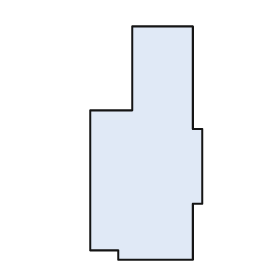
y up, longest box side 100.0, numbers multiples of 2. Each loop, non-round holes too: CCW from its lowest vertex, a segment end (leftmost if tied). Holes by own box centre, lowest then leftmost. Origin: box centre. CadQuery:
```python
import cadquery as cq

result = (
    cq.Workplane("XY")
    .moveTo(-12.0, -50.0)
    .lineTo(20.0, -50.0)
    .lineTo(20.0, -26.0)
    .lineTo(24.0, -26.0)
    .lineTo(24.0, 6.0)
    .lineTo(20.0, 6.0)
    .lineTo(20.0, 50.0)
    .lineTo(-6.0, 50.0)
    .lineTo(-6.0, 14.0)
    .lineTo(-24.0, 14.0)
    .lineTo(-24.0, -46.0)
    .lineTo(-12.0, -46.0)
    .close()
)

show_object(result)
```